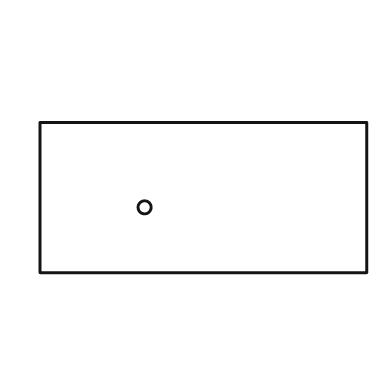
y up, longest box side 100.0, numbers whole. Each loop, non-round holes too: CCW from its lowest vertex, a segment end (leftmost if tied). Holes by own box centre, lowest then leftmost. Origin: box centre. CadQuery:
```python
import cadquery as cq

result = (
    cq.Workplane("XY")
    .moveTo(-50.0, -23.0)
    .lineTo(50.0, -23.0)
    .lineTo(50.0, 23.0)
    .lineTo(-50.0, 23.0)
    .close()
    .moveTo(-18.0, -3.0)
    .circle(2.0)
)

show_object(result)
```